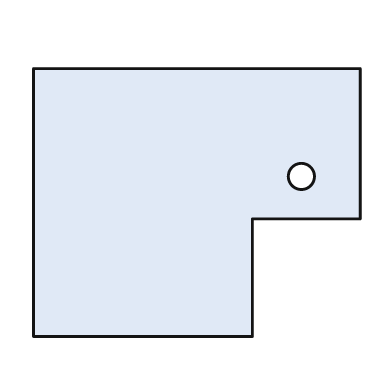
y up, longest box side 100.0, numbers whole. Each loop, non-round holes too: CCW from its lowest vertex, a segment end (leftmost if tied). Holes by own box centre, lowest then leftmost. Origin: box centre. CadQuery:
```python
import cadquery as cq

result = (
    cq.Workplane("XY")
    .moveTo(-50.0, -41.0)
    .lineTo(17.0, -41.0)
    .lineTo(17.0, -5.0)
    .lineTo(50.0, -5.0)
    .lineTo(50.0, 41.0)
    .lineTo(-50.0, 41.0)
    .close()
    .moveTo(32.0, 8.0)
    .circle(4.0)
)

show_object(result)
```